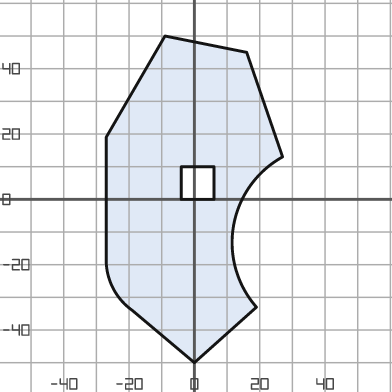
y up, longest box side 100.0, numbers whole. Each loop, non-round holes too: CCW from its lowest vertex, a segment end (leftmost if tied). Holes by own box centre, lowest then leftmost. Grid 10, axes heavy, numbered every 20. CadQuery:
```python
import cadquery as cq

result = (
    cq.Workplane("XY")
    .moveTo(0.0, -50.0)
    .lineTo(19.0, -33.0)
    .threePointArc((12.0, -8.0), (27.0, 13.0))
    .lineTo(16.0, 45.0)
    .lineTo(-9.0, 50.0)
    .lineTo(-27.0, 19.0)
    .lineTo(-27.0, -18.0)
    .threePointArc((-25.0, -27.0), (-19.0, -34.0))
    .close()
    .moveTo(-4.0, 0.0)
    .lineTo(6.0, 0.0)
    .lineTo(6.0, 10.0)
    .lineTo(-4.0, 10.0)
    .close()
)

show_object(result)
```